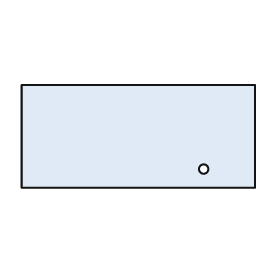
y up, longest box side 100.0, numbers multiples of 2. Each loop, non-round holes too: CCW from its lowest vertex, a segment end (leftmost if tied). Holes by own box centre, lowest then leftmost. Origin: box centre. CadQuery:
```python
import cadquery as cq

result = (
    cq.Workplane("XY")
    .moveTo(-50.0, -22.0)
    .lineTo(50.0, -22.0)
    .lineTo(50.0, 22.0)
    .lineTo(-50.0, 22.0)
    .close()
    .moveTo(28.0, -14.0)
    .circle(2.0)
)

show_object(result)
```